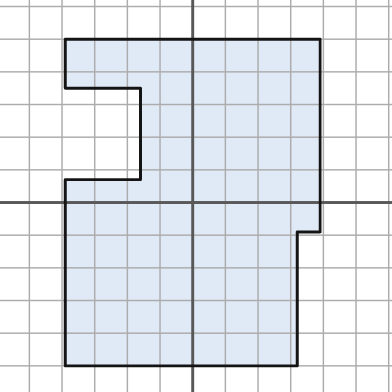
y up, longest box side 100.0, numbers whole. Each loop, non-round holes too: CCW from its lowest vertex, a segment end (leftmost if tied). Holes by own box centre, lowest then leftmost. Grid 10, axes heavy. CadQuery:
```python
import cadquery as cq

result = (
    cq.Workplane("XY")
    .moveTo(-39.0, -50.0)
    .lineTo(32.0, -50.0)
    .lineTo(32.0, -9.0)
    .lineTo(39.0, -9.0)
    .lineTo(39.0, 50.0)
    .lineTo(-39.0, 50.0)
    .lineTo(-39.0, 35.0)
    .lineTo(-16.0, 35.0)
    .lineTo(-16.0, 7.0)
    .lineTo(-39.0, 7.0)
    .close()
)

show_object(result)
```